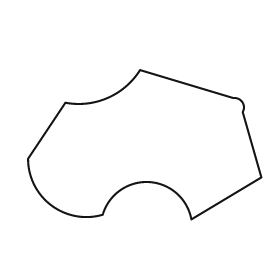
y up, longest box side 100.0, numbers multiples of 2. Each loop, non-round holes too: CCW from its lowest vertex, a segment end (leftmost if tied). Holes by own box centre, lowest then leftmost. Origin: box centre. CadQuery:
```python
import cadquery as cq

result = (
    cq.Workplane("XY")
    .moveTo(20.0, -32.0)
    .lineTo(50.0, -14.0)
    .lineTo(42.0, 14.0)
    .threePointArc((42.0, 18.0), (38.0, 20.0))
    .lineTo(-2.0, 32.0)
    .threePointArc((-16.0, 20.0), (-34.0, 18.0))
    .lineTo(-50.0, -6.0)
    .threePointArc((-40.0, -26.0), (-18.0, -30.0))
    .threePointArc((2.0, -16.0), (20.0, -32.0))
    .close()
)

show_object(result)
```